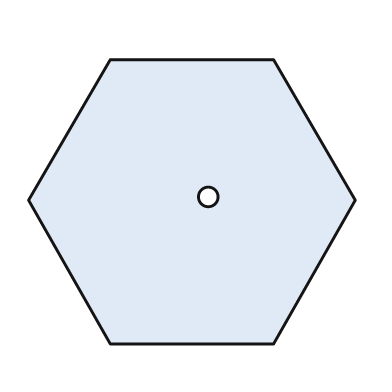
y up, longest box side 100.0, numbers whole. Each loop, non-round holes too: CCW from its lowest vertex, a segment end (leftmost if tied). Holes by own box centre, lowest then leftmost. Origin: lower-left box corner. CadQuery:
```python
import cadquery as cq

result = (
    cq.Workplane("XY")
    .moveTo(25.0, 0.0)
    .lineTo(75.0, 0.0)
    .lineTo(100.0, 44.0)
    .lineTo(75.0, 87.0)
    .lineTo(25.0, 87.0)
    .lineTo(0.0, 44.0)
    .close()
    .moveTo(55.0, 45.0)
    .circle(3.0)
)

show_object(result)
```